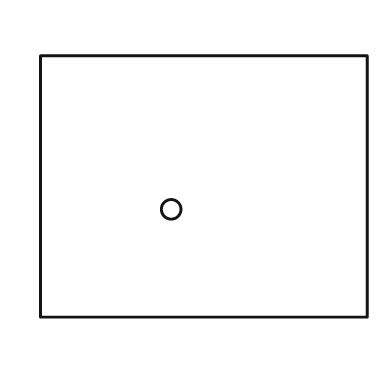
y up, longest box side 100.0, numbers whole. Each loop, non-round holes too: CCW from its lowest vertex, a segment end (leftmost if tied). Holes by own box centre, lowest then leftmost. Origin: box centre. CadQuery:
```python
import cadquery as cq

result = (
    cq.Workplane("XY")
    .moveTo(-50.0, -40.0)
    .lineTo(50.0, -40.0)
    .lineTo(50.0, 40.0)
    .lineTo(-50.0, 40.0)
    .close()
    .moveTo(-10.0, -7.0)
    .circle(3.0)
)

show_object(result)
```